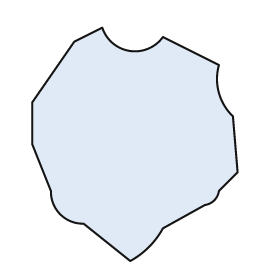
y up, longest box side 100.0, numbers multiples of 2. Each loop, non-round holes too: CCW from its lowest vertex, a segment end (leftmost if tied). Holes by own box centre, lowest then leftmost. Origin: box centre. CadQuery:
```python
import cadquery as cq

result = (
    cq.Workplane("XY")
    .moveTo(-2.0, -50.0)
    .threePointArc((6.0, -44.0), (12.0, -36.0))
    .lineTo(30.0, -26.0)
    .threePointArc((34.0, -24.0), (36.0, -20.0))
    .lineTo(44.0, -12.0)
    .lineTo(42.0, 12.0)
    .threePointArc((36.0, 22.0), (36.0, 34.0))
    .lineTo(12.0, 46.0)
    .threePointArc((-2.0, 40.0), (-14.0, 50.0))
    .lineTo(-26.0, 44.0)
    .lineTo(-44.0, 18.0)
    .lineTo(-44.0, 0.0)
    .lineTo(-36.0, -20.0)
    .threePointArc((-32.0, -30.0), (-22.0, -34.0))
    .close()
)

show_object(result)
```